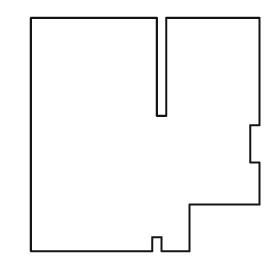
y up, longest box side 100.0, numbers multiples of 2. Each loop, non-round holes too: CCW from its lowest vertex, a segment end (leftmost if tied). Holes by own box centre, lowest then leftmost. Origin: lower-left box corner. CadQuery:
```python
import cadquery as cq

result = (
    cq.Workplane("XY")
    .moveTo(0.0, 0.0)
    .lineTo(52.0, 0.0)
    .lineTo(52.0, 6.0)
    .lineTo(56.0, 6.0)
    .lineTo(56.0, 0.0)
    .lineTo(68.0, 0.0)
    .lineTo(68.0, 20.0)
    .lineTo(98.0, 20.0)
    .lineTo(98.0, 38.0)
    .lineTo(94.0, 38.0)
    .lineTo(94.0, 54.0)
    .lineTo(98.0, 54.0)
    .lineTo(98.0, 100.0)
    .lineTo(58.0, 100.0)
    .lineTo(58.0, 58.0)
    .lineTo(54.0, 58.0)
    .lineTo(54.0, 100.0)
    .lineTo(0.0, 100.0)
    .close()
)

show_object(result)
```